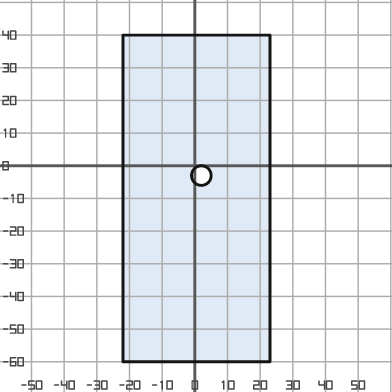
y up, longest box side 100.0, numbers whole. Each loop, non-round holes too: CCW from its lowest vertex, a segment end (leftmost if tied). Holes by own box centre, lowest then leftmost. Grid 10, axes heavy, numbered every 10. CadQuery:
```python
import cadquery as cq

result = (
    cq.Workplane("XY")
    .moveTo(-22.0, -60.0)
    .lineTo(23.0, -60.0)
    .lineTo(23.0, 40.0)
    .lineTo(-22.0, 40.0)
    .close()
    .moveTo(2.0, -3.0)
    .circle(3.0)
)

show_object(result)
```